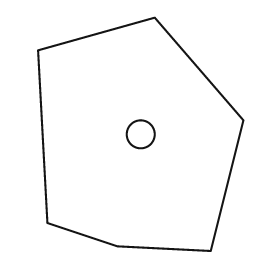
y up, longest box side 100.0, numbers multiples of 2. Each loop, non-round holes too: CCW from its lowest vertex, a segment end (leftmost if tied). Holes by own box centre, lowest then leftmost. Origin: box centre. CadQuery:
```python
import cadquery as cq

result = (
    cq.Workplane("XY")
    .moveTo(30.0, -50.0)
    .lineTo(44.0, 6.0)
    .lineTo(6.0, 50.0)
    .lineTo(-44.0, 36.0)
    .lineTo(-40.0, -38.0)
    .lineTo(-10.0, -48.0)
    .close()
    .moveTo(0.0, 0.0)
    .circle(6.0)
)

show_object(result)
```